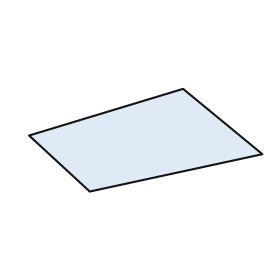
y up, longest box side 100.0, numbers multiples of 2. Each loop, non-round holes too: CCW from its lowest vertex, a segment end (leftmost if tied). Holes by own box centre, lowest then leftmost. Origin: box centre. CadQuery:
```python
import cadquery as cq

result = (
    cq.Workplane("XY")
    .moveTo(-24.0, -22.0)
    .lineTo(50.0, -6.0)
    .lineTo(16.0, 22.0)
    .lineTo(-50.0, 2.0)
    .close()
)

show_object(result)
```